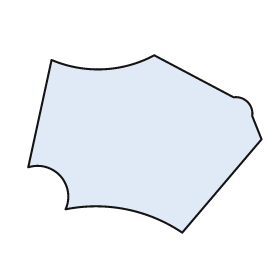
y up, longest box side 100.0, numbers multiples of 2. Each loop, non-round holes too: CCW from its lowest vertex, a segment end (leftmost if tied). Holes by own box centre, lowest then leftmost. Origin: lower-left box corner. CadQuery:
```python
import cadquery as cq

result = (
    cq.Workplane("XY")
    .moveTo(66.0, 0.0)
    .lineTo(100.0, 40.0)
    .lineTo(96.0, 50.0)
    .threePointArc((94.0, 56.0), (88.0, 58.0))
    .lineTo(54.0, 76.0)
    .threePointArc((32.0, 70.0), (10.0, 74.0))
    .lineTo(0.0, 28.0)
    .threePointArc((14.0, 24.0), (16.0, 10.0))
    .threePointArc((42.0, 10.0), (66.0, 0.0))
    .close()
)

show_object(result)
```